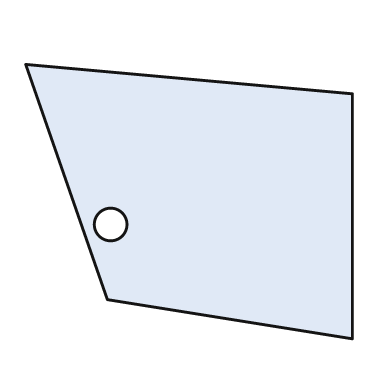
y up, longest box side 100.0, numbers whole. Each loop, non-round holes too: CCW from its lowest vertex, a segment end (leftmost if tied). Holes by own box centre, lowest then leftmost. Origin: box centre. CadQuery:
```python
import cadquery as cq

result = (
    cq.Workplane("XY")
    .moveTo(50.0, -42.0)
    .lineTo(50.0, 33.0)
    .lineTo(-50.0, 42.0)
    .lineTo(-25.0, -30.0)
    .close()
    .moveTo(-24.0, -7.0)
    .circle(5.0)
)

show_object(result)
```